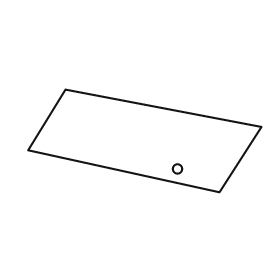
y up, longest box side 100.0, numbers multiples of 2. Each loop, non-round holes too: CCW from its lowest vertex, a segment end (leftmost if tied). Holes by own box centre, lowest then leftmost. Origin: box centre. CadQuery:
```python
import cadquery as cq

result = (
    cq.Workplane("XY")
    .moveTo(32.0, -22.0)
    .lineTo(50.0, 6.0)
    .lineTo(-34.0, 22.0)
    .lineTo(-50.0, -4.0)
    .close()
    .moveTo(14.0, -12.0)
    .circle(2.0)
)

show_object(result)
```